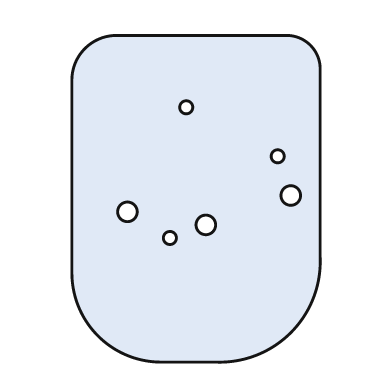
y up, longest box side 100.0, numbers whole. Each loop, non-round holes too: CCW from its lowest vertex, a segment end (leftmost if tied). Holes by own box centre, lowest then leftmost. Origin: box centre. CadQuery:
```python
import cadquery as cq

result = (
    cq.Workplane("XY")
    .moveTo(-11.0, -50.0)
    .lineTo(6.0, -50.0)
    .threePointArc((29.0, -41.0), (38.0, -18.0))
    .lineTo(38.0, 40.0)
    .threePointArc((35.0, 47.0), (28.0, 50.0))
    .lineTo(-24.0, 50.0)
    .threePointArc((-34.0, 46.0), (-38.0, 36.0))
    .lineTo(-38.0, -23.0)
    .threePointArc((-30.0, -42.0), (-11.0, -50.0))
    .close()
    .moveTo(-8.0, -12.0)
    .circle(2.0)
    .moveTo(3.0, -8.0)
    .circle(3.0)
    .moveTo(-21.0, -4.0)
    .circle(3.0)
    .moveTo(29.0, 1.0)
    .circle(3.0)
    .moveTo(25.0, 13.0)
    .circle(2.0)
    .moveTo(-3.0, 28.0)
    .circle(2.0)
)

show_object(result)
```